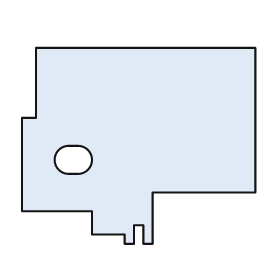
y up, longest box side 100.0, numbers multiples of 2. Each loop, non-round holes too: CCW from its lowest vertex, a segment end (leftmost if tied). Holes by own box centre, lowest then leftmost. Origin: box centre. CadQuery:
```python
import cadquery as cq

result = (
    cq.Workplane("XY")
    .moveTo(-6.0, -42.0)
    .lineTo(-2.0, -42.0)
    .lineTo(-2.0, -34.0)
    .lineTo(2.0, -34.0)
    .lineTo(2.0, -42.0)
    .lineTo(6.0, -42.0)
    .lineTo(6.0, -20.0)
    .lineTo(50.0, -20.0)
    .lineTo(50.0, 42.0)
    .lineTo(-44.0, 42.0)
    .lineTo(-44.0, 12.0)
    .lineTo(-50.0, 12.0)
    .lineTo(-50.0, -28.0)
    .lineTo(-20.0, -28.0)
    .lineTo(-20.0, -38.0)
    .lineTo(-6.0, -38.0)
    .close()
    .moveTo(-30.0, -12.0)
    .lineTo(-26.0, -12.0)
    .threePointArc((-20.0, -6.0), (-26.0, 0.0))
    .lineTo(-30.0, 0.0)
    .threePointArc((-36.0, -6.0), (-30.0, -12.0))
    .close()
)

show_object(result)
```